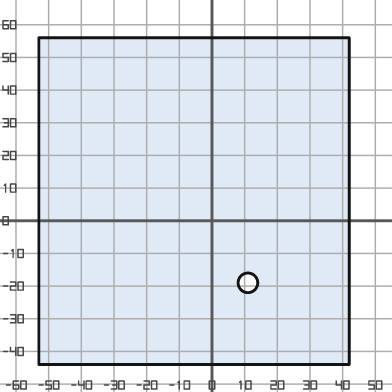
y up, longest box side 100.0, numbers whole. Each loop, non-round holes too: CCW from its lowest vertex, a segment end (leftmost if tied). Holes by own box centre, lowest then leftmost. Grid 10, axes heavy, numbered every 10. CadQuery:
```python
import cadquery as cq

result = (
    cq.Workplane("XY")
    .moveTo(-53.0, -44.0)
    .lineTo(42.0, -44.0)
    .lineTo(42.0, 56.0)
    .lineTo(-53.0, 56.0)
    .close()
    .moveTo(11.0, -19.0)
    .circle(3.0)
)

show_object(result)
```